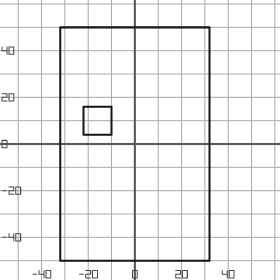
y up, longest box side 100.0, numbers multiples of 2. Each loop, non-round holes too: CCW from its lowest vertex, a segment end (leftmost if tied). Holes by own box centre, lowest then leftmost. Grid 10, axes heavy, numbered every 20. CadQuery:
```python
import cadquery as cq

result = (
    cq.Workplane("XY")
    .moveTo(-32.0, -50.0)
    .lineTo(32.0, -50.0)
    .lineTo(32.0, 50.0)
    .lineTo(-32.0, 50.0)
    .close()
    .moveTo(-22.0, 4.0)
    .lineTo(-10.0, 4.0)
    .lineTo(-10.0, 16.0)
    .lineTo(-22.0, 16.0)
    .close()
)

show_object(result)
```